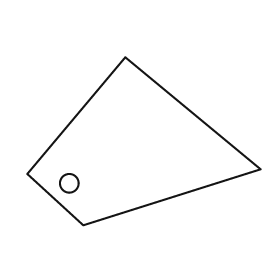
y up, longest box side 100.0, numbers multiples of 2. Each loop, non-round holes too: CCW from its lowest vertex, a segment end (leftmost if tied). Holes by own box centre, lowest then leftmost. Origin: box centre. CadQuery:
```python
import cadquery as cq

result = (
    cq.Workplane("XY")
    .moveTo(-26.0, -36.0)
    .lineTo(50.0, -12.0)
    .lineTo(-8.0, 36.0)
    .lineTo(-50.0, -14.0)
    .close()
    .moveTo(-32.0, -18.0)
    .circle(4.0)
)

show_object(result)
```